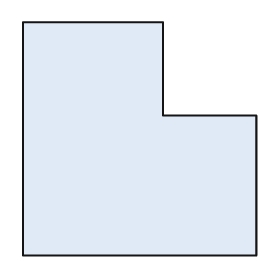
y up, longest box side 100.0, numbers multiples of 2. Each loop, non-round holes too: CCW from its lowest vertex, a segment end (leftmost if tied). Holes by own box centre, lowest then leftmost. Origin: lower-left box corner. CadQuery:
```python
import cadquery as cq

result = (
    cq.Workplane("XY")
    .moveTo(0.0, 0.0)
    .lineTo(100.0, 0.0)
    .lineTo(100.0, 60.0)
    .lineTo(60.0, 60.0)
    .lineTo(60.0, 100.0)
    .lineTo(0.0, 100.0)
    .close()
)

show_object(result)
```